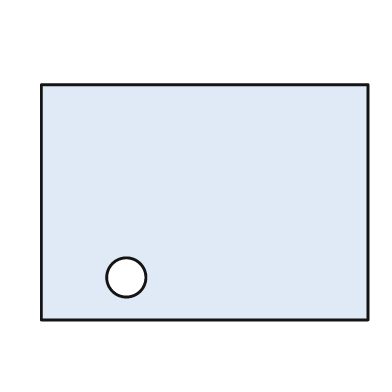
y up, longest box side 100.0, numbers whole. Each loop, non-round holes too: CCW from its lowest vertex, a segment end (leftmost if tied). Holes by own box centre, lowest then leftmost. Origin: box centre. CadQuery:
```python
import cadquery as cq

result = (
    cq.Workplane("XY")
    .moveTo(-50.0, -36.0)
    .lineTo(50.0, -36.0)
    .lineTo(50.0, 36.0)
    .lineTo(-50.0, 36.0)
    .close()
    .moveTo(-24.0, -23.0)
    .circle(6.0)
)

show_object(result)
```